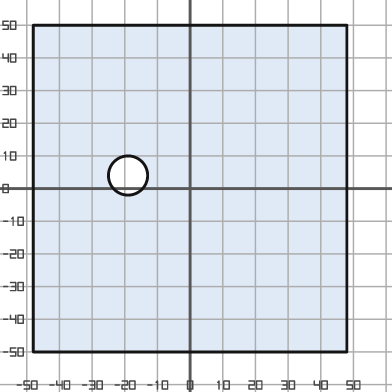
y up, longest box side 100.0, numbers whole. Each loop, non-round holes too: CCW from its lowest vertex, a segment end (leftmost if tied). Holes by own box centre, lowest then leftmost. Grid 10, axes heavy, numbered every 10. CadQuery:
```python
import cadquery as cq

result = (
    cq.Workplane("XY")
    .moveTo(-48.0, -50.0)
    .lineTo(48.0, -50.0)
    .lineTo(48.0, 50.0)
    .lineTo(-48.0, 50.0)
    .close()
    .moveTo(-19.0, 4.0)
    .circle(6.0)
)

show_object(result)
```